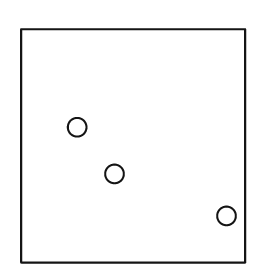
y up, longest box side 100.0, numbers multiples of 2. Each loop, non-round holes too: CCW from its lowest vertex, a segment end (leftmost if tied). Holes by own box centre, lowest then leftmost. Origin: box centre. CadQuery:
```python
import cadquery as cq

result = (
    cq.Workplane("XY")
    .moveTo(-48.0, -50.0)
    .lineTo(48.0, -50.0)
    .lineTo(48.0, 50.0)
    .lineTo(-48.0, 50.0)
    .close()
    .moveTo(40.0, -30.0)
    .circle(4.0)
    .moveTo(-8.0, -12.0)
    .circle(4.0)
    .moveTo(-24.0, 8.0)
    .circle(4.0)
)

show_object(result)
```